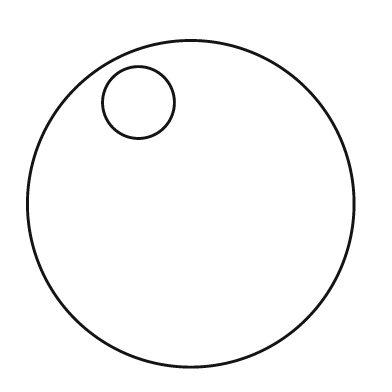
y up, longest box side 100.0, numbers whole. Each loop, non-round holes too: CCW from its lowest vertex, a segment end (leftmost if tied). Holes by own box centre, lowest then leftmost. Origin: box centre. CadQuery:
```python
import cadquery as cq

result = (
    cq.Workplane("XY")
    .moveTo(0.0, 0.0)
    .circle(50.0)
    .moveTo(-16.0, 31.0)
    .circle(11.0)
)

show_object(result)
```